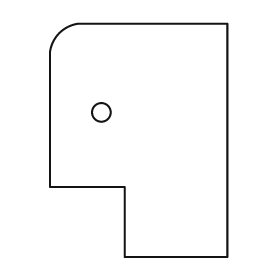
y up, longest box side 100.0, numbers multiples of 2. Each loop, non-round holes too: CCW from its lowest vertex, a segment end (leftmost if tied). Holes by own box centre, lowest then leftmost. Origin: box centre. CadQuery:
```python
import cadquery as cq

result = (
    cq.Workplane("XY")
    .moveTo(-6.0, -50.0)
    .lineTo(38.0, -50.0)
    .lineTo(38.0, 50.0)
    .lineTo(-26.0, 50.0)
    .threePointArc((-34.0, 46.0), (-38.0, 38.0))
    .lineTo(-38.0, -20.0)
    .lineTo(-6.0, -20.0)
    .close()
    .moveTo(-16.0, 12.0)
    .circle(4.0)
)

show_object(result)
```